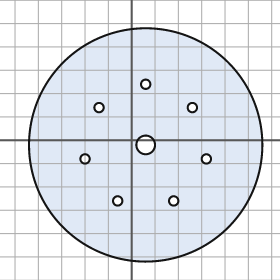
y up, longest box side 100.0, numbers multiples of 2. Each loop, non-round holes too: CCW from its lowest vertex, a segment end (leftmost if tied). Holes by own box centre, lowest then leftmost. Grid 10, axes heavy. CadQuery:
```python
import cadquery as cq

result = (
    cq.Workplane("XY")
    .moveTo(6.0, -2.0)
    .circle(50.0)
    .moveTo(-6.0, -26.0)
    .circle(2.0)
    .moveTo(18.0, -26.0)
    .circle(2.0)
    .moveTo(-20.0, -8.0)
    .circle(2.0)
    .moveTo(32.0, -8.0)
    .circle(2.0)
    .moveTo(6.0, -2.0)
    .circle(4.0)
    .moveTo(-14.0, 14.0)
    .circle(2.0)
    .moveTo(26.0, 14.0)
    .circle(2.0)
    .moveTo(6.0, 24.0)
    .circle(2.0)
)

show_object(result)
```